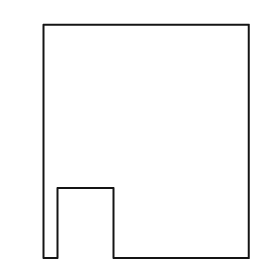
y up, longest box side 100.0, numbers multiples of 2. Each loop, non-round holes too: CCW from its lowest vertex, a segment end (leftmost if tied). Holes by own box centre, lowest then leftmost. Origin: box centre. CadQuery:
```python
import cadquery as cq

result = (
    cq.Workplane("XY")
    .moveTo(-44.0, -50.0)
    .lineTo(-38.0, -50.0)
    .lineTo(-38.0, -20.0)
    .lineTo(-14.0, -20.0)
    .lineTo(-14.0, -50.0)
    .lineTo(44.0, -50.0)
    .lineTo(44.0, 50.0)
    .lineTo(-44.0, 50.0)
    .close()
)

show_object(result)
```